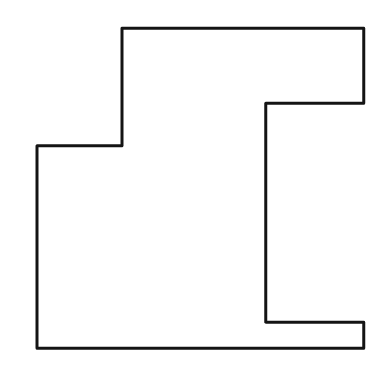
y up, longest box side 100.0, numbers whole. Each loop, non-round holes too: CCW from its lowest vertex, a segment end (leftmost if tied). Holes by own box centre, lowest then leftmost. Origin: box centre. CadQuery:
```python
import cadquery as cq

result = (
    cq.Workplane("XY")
    .moveTo(-50.0, -49.0)
    .lineTo(50.0, -49.0)
    .lineTo(50.0, -41.0)
    .lineTo(20.0, -41.0)
    .lineTo(20.0, 26.0)
    .lineTo(50.0, 26.0)
    .lineTo(50.0, 49.0)
    .lineTo(-24.0, 49.0)
    .lineTo(-24.0, 13.0)
    .lineTo(-50.0, 13.0)
    .close()
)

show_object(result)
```